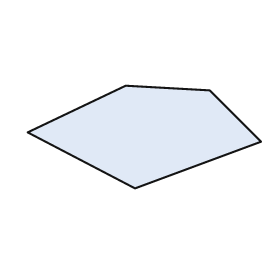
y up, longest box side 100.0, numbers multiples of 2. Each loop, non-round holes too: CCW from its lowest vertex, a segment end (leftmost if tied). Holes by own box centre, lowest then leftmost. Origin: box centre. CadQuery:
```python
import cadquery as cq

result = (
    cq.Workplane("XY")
    .moveTo(-4.0, -22.0)
    .lineTo(50.0, -2.0)
    .lineTo(28.0, 20.0)
    .lineTo(-8.0, 22.0)
    .lineTo(-50.0, 2.0)
    .close()
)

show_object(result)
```